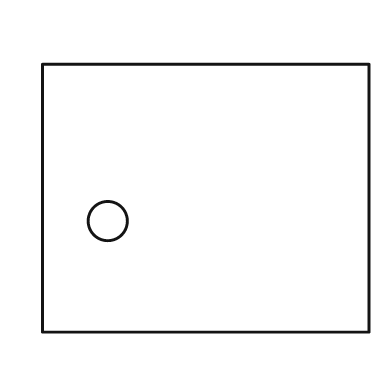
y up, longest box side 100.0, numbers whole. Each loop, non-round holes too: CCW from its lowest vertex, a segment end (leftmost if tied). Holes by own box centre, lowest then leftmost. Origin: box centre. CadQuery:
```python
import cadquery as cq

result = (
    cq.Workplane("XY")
    .moveTo(-50.0, -41.0)
    .lineTo(50.0, -41.0)
    .lineTo(50.0, 41.0)
    .lineTo(-50.0, 41.0)
    .close()
    .moveTo(-30.0, -7.0)
    .circle(6.0)
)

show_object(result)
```